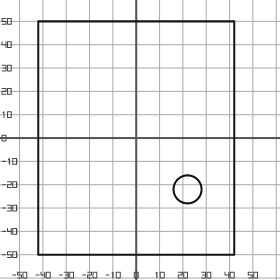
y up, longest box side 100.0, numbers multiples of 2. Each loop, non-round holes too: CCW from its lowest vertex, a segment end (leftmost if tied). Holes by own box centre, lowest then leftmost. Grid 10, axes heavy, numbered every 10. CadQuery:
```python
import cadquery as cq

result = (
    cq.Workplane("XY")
    .moveTo(-42.0, -50.0)
    .lineTo(42.0, -50.0)
    .lineTo(42.0, 50.0)
    .lineTo(-42.0, 50.0)
    .close()
    .moveTo(22.0, -22.0)
    .circle(6.0)
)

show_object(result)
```